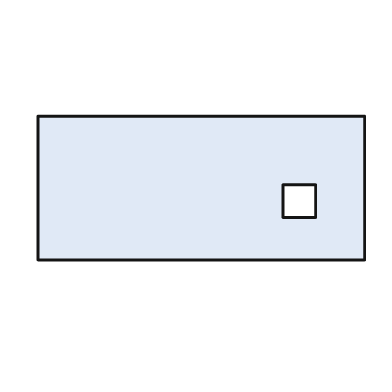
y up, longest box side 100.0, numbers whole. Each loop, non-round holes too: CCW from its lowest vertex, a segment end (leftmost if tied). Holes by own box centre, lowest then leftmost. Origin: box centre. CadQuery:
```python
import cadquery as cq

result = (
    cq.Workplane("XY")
    .moveTo(-50.0, -22.0)
    .lineTo(50.0, -22.0)
    .lineTo(50.0, 22.0)
    .lineTo(-50.0, 22.0)
    .close()
    .moveTo(25.0, -9.0)
    .lineTo(35.0, -9.0)
    .lineTo(35.0, 1.0)
    .lineTo(25.0, 1.0)
    .close()
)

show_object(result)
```